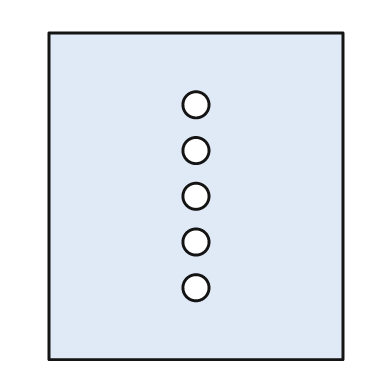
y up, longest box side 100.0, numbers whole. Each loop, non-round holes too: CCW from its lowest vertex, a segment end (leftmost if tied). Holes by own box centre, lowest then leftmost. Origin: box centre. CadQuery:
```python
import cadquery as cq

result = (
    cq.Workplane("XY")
    .moveTo(-45.0, -50.0)
    .lineTo(45.0, -50.0)
    .lineTo(45.0, 50.0)
    .lineTo(-45.0, 50.0)
    .close()
    .moveTo(0.0, -28.0)
    .circle(4.0)
    .moveTo(0.0, -14.0)
    .circle(4.0)
    .moveTo(0.0, 0.0)
    .circle(4.0)
    .moveTo(0.0, 14.0)
    .circle(4.0)
    .moveTo(0.0, 28.0)
    .circle(4.0)
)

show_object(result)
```